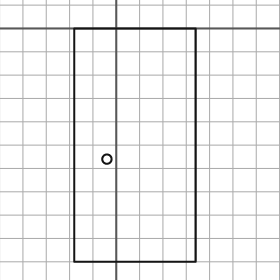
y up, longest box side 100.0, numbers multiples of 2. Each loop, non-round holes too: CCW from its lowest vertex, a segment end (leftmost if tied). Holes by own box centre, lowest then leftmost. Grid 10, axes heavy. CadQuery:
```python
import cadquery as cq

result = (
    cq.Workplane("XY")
    .moveTo(-18.0, -100.0)
    .lineTo(34.0, -100.0)
    .lineTo(34.0, 0.0)
    .lineTo(-18.0, 0.0)
    .close()
    .moveTo(-4.0, -56.0)
    .circle(2.0)
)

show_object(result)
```